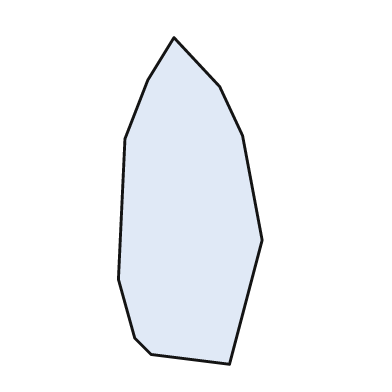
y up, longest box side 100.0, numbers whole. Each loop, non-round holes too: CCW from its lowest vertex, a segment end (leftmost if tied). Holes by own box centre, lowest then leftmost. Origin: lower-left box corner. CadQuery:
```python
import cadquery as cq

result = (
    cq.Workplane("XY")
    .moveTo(34.0, 0.0)
    .lineTo(44.0, 38.0)
    .lineTo(38.0, 70.0)
    .lineTo(31.0, 85.0)
    .lineTo(17.0, 100.0)
    .lineTo(9.0, 87.0)
    .lineTo(2.0, 69.0)
    .lineTo(0.0, 26.0)
    .lineTo(5.0, 8.0)
    .lineTo(10.0, 3.0)
    .close()
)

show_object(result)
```